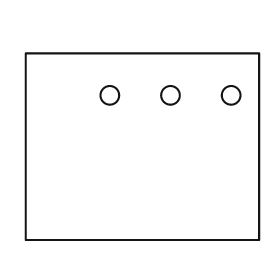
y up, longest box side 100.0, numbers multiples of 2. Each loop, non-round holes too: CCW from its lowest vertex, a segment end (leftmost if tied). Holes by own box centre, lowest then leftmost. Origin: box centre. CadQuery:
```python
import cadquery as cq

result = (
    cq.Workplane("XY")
    .moveTo(-50.0, -40.0)
    .lineTo(50.0, -40.0)
    .lineTo(50.0, 40.0)
    .lineTo(-50.0, 40.0)
    .close()
    .moveTo(-14.0, 22.0)
    .circle(4.0)
    .moveTo(12.0, 22.0)
    .circle(4.0)
    .moveTo(38.0, 22.0)
    .circle(4.0)
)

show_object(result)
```